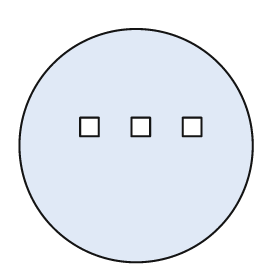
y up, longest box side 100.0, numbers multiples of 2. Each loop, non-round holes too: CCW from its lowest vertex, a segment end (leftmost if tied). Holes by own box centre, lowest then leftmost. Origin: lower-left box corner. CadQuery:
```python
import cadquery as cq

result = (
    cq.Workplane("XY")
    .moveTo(50.0, 50.0)
    .circle(50.0)
    .moveTo(26.0, 54.0)
    .lineTo(34.0, 54.0)
    .lineTo(34.0, 62.0)
    .lineTo(26.0, 62.0)
    .close()
    .moveTo(48.0, 54.0)
    .lineTo(56.0, 54.0)
    .lineTo(56.0, 62.0)
    .lineTo(48.0, 62.0)
    .close()
    .moveTo(70.0, 54.0)
    .lineTo(78.0, 54.0)
    .lineTo(78.0, 62.0)
    .lineTo(70.0, 62.0)
    .close()
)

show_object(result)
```